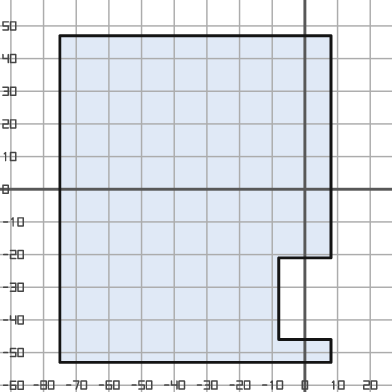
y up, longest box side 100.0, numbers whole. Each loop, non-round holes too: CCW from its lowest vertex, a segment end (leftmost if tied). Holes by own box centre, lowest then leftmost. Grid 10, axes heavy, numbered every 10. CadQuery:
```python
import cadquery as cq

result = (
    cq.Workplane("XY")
    .moveTo(-75.0, -53.0)
    .lineTo(8.0, -53.0)
    .lineTo(8.0, -46.0)
    .lineTo(-8.0, -46.0)
    .lineTo(-8.0, -21.0)
    .lineTo(8.0, -21.0)
    .lineTo(8.0, 47.0)
    .lineTo(-75.0, 47.0)
    .close()
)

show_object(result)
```